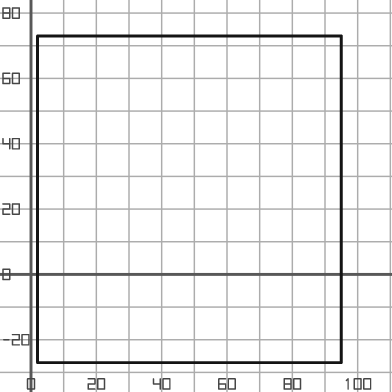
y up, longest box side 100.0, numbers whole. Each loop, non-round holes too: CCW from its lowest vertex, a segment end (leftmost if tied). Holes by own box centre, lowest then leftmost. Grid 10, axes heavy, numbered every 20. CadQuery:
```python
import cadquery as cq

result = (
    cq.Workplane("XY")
    .moveTo(2.0, -27.0)
    .lineTo(95.0, -27.0)
    .lineTo(95.0, 73.0)
    .lineTo(2.0, 73.0)
    .close()
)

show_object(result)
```